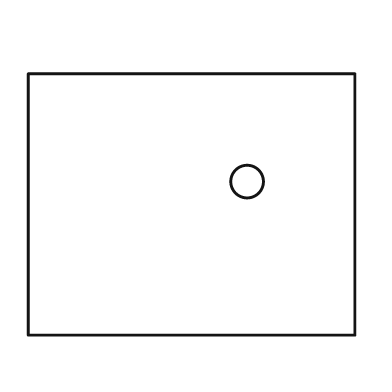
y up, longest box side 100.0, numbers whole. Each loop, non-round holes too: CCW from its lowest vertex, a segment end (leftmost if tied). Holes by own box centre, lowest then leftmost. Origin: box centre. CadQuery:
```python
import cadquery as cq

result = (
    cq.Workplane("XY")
    .moveTo(-50.0, -40.0)
    .lineTo(50.0, -40.0)
    .lineTo(50.0, 40.0)
    .lineTo(-50.0, 40.0)
    .close()
    .moveTo(17.0, 7.0)
    .circle(5.0)
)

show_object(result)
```